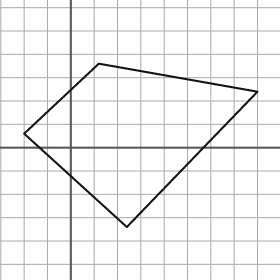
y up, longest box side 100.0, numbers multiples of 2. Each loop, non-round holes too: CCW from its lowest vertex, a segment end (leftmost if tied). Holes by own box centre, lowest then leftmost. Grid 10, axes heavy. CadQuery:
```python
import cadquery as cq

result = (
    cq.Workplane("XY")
    .moveTo(24.0, -34.0)
    .lineTo(80.0, 24.0)
    .lineTo(12.0, 36.0)
    .lineTo(-20.0, 6.0)
    .close()
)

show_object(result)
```